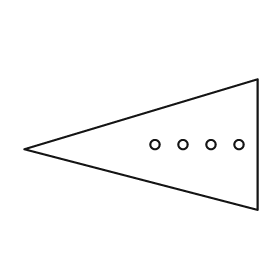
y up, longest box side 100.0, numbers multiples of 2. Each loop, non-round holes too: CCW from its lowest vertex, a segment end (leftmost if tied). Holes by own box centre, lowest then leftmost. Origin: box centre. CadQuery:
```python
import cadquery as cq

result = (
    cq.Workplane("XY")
    .moveTo(50.0, -28.0)
    .lineTo(50.0, 28.0)
    .lineTo(-50.0, -2.0)
    .close()
    .moveTo(6.0, 0.0)
    .circle(2.0)
    .moveTo(18.0, 0.0)
    .circle(2.0)
    .moveTo(30.0, 0.0)
    .circle(2.0)
    .moveTo(42.0, 0.0)
    .circle(2.0)
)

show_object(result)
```